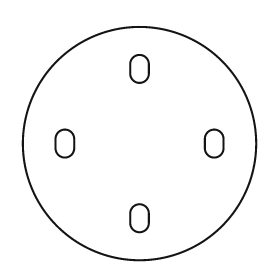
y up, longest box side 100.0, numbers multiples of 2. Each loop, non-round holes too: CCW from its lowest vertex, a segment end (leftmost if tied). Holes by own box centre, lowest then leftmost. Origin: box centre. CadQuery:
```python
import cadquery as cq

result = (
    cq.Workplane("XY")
    .moveTo(0.0, 0.0)
    .circle(50.0)
    .moveTo(-4.0, -34.0)
    .threePointArc((0.0, -38.0), (4.0, -34.0))
    .lineTo(4.0, -30.0)
    .threePointArc((0.0, -26.0), (-4.0, -30.0))
    .close()
    .moveTo(-36.0, -2.0)
    .threePointArc((-32.0, -6.0), (-28.0, -2.0))
    .lineTo(-28.0, 2.0)
    .threePointArc((-32.0, 6.0), (-36.0, 2.0))
    .close()
    .moveTo(28.0, -2.0)
    .threePointArc((32.0, -6.0), (36.0, -2.0))
    .lineTo(36.0, 2.0)
    .threePointArc((32.0, 6.0), (28.0, 2.0))
    .close()
    .moveTo(-4.0, 30.0)
    .threePointArc((0.0, 26.0), (4.0, 30.0))
    .lineTo(4.0, 34.0)
    .threePointArc((0.0, 38.0), (-4.0, 34.0))
    .close()
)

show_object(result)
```